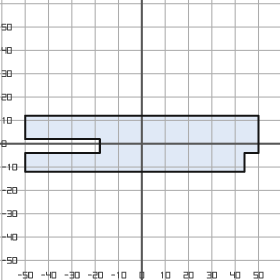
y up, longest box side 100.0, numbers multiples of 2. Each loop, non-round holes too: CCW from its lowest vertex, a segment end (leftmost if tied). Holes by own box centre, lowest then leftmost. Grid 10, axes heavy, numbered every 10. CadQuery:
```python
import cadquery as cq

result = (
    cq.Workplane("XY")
    .moveTo(-50.0, -12.0)
    .lineTo(44.0, -12.0)
    .lineTo(44.0, -4.0)
    .lineTo(50.0, -4.0)
    .lineTo(50.0, 12.0)
    .lineTo(-50.0, 12.0)
    .lineTo(-50.0, 2.0)
    .lineTo(-18.0, 2.0)
    .lineTo(-18.0, -4.0)
    .lineTo(-50.0, -4.0)
    .close()
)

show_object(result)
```